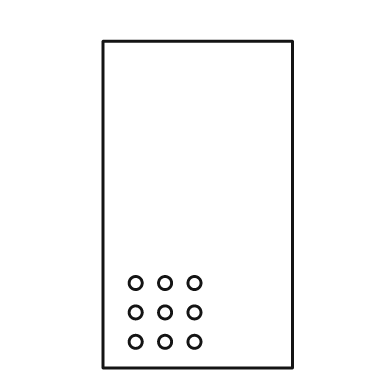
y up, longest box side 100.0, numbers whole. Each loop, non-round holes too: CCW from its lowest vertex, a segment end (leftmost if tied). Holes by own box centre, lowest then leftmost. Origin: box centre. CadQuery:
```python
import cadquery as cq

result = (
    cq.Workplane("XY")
    .moveTo(-29.0, -50.0)
    .lineTo(29.0, -50.0)
    .lineTo(29.0, 50.0)
    .lineTo(-29.0, 50.0)
    .close()
    .moveTo(-19.0, -42.0)
    .circle(2.0)
    .moveTo(-10.0, -42.0)
    .circle(2.0)
    .moveTo(-1.0, -42.0)
    .circle(2.0)
    .moveTo(-19.0, -33.0)
    .circle(2.0)
    .moveTo(-10.0, -33.0)
    .circle(2.0)
    .moveTo(-1.0, -33.0)
    .circle(2.0)
    .moveTo(-19.0, -24.0)
    .circle(2.0)
    .moveTo(-10.0, -24.0)
    .circle(2.0)
    .moveTo(-1.0, -24.0)
    .circle(2.0)
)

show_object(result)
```